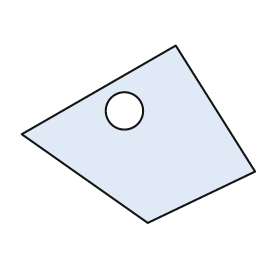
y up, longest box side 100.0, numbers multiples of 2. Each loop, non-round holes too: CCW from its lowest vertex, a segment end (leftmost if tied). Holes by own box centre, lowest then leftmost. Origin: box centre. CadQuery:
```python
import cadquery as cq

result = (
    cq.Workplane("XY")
    .moveTo(4.0, -38.0)
    .lineTo(50.0, -16.0)
    .lineTo(16.0, 38.0)
    .lineTo(-50.0, 0.0)
    .close()
    .moveTo(-6.0, 10.0)
    .circle(8.0)
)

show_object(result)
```